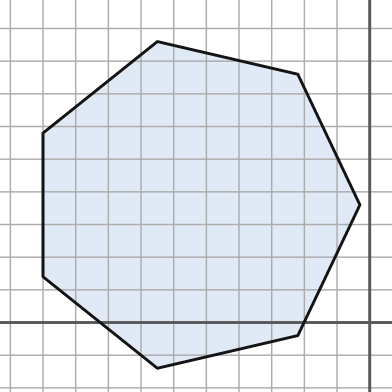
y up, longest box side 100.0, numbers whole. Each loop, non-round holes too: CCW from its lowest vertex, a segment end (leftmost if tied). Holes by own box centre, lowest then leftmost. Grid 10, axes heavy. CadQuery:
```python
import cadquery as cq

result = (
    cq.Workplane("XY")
    .moveTo(-65.0, -14.0)
    .lineTo(-22.0, -4.0)
    .lineTo(-3.0, 36.0)
    .lineTo(-22.0, 76.0)
    .lineTo(-65.0, 86.0)
    .lineTo(-100.0, 58.0)
    .lineTo(-100.0, 14.0)
    .close()
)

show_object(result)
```